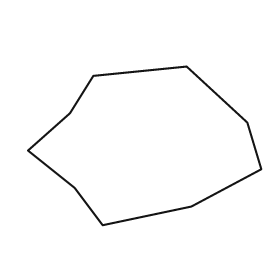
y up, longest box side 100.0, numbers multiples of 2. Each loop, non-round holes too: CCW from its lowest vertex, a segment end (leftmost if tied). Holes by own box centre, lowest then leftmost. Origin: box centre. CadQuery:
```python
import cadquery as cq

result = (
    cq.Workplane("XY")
    .moveTo(-18.0, -34.0)
    .lineTo(20.0, -26.0)
    .lineTo(50.0, -10.0)
    .lineTo(44.0, 10.0)
    .lineTo(18.0, 34.0)
    .lineTo(-22.0, 30.0)
    .lineTo(-32.0, 14.0)
    .lineTo(-50.0, -2.0)
    .lineTo(-30.0, -18.0)
    .close()
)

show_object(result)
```